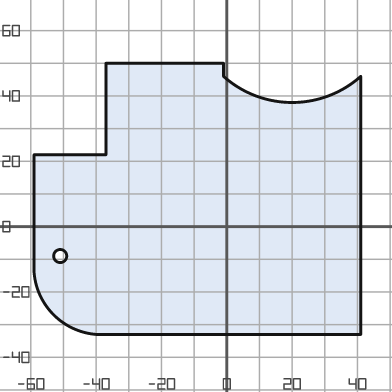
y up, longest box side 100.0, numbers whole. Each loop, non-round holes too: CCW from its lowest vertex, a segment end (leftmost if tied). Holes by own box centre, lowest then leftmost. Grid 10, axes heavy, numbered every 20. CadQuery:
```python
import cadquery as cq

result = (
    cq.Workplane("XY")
    .moveTo(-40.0, -33.0)
    .lineTo(41.0, -33.0)
    .lineTo(41.0, 46.0)
    .threePointArc((20.0, 38.0), (-1.0, 46.0))
    .lineTo(-1.0, 50.0)
    .lineTo(-37.0, 50.0)
    .lineTo(-37.0, 22.0)
    .lineTo(-59.0, 22.0)
    .lineTo(-59.0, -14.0)
    .threePointArc((-53.0, -27.0), (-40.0, -33.0))
    .close()
    .moveTo(-51.0, -9.0)
    .circle(2.0)
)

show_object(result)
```